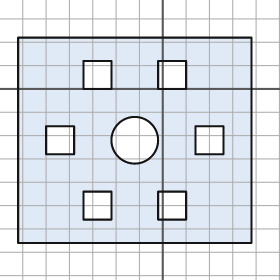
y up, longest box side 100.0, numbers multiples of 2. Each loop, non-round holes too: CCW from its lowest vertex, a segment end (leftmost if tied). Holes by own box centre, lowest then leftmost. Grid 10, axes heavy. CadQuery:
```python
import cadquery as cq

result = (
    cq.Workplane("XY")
    .moveTo(-62.0, -66.0)
    .lineTo(38.0, -66.0)
    .lineTo(38.0, 22.0)
    .lineTo(-62.0, 22.0)
    .close()
    .moveTo(-34.0, -56.0)
    .lineTo(-22.0, -56.0)
    .lineTo(-22.0, -44.0)
    .lineTo(-34.0, -44.0)
    .close()
    .moveTo(-2.0, -56.0)
    .lineTo(10.0, -56.0)
    .lineTo(10.0, -44.0)
    .lineTo(-2.0, -44.0)
    .close()
    .moveTo(-50.0, -28.0)
    .lineTo(-38.0, -28.0)
    .lineTo(-38.0, -16.0)
    .lineTo(-50.0, -16.0)
    .close()
    .moveTo(-12.0, -22.0)
    .circle(10.0)
    .moveTo(14.0, -28.0)
    .lineTo(26.0, -28.0)
    .lineTo(26.0, -16.0)
    .lineTo(14.0, -16.0)
    .close()
    .moveTo(-34.0, 0.0)
    .lineTo(-22.0, 0.0)
    .lineTo(-22.0, 12.0)
    .lineTo(-34.0, 12.0)
    .close()
    .moveTo(-2.0, 0.0)
    .lineTo(10.0, 0.0)
    .lineTo(10.0, 12.0)
    .lineTo(-2.0, 12.0)
    .close()
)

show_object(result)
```